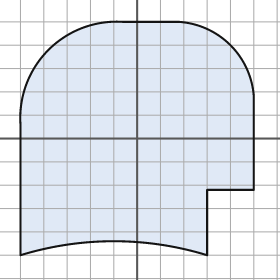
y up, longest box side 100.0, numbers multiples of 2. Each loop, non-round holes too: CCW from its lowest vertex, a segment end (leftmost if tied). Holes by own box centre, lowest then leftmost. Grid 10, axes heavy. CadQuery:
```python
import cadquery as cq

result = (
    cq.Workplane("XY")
    .moveTo(-50.0, -50.0)
    .threePointArc((-10.0, -44.0), (30.0, -50.0))
    .lineTo(30.0, -22.0)
    .lineTo(50.0, -22.0)
    .lineTo(50.0, 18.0)
    .threePointArc((40.0, 40.0), (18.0, 50.0))
    .lineTo(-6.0, 50.0)
    .threePointArc((-38.0, 38.0), (-50.0, 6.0))
    .close()
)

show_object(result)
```